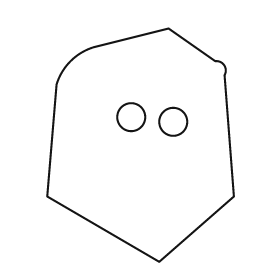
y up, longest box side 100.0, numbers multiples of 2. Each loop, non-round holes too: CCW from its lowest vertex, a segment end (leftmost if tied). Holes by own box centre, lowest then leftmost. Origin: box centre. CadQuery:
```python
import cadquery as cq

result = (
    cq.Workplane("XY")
    .moveTo(8.0, -50.0)
    .lineTo(40.0, -22.0)
    .lineTo(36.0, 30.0)
    .threePointArc((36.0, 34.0), (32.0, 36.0))
    .lineTo(12.0, 50.0)
    .lineTo(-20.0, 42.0)
    .threePointArc((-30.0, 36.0), (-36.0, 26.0))
    .lineTo(-40.0, -22.0)
    .close()
    .moveTo(14.0, 10.0)
    .circle(6.0)
    .moveTo(-4.0, 12.0)
    .circle(6.0)
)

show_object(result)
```